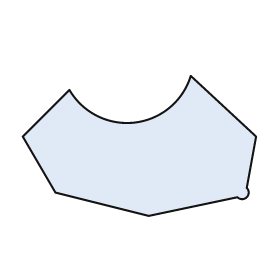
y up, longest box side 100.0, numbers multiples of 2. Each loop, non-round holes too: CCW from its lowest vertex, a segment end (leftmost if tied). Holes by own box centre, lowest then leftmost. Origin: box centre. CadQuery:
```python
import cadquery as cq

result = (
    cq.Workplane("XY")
    .moveTo(4.0, -30.0)
    .lineTo(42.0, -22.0)
    .threePointArc((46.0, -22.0), (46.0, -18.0))
    .lineTo(50.0, 4.0)
    .lineTo(22.0, 30.0)
    .threePointArc((-2.0, 10.0), (-30.0, 24.0))
    .lineTo(-50.0, 4.0)
    .lineTo(-36.0, -20.0)
    .close()
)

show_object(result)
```